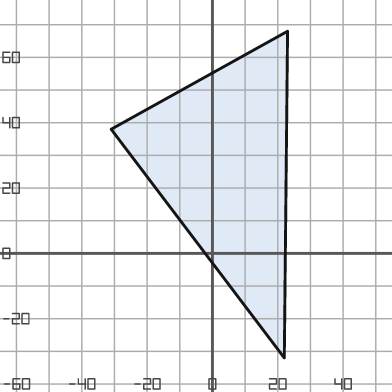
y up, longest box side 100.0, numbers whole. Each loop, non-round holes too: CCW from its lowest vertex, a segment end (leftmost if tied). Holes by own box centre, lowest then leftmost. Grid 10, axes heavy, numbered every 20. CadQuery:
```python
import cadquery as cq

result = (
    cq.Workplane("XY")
    .moveTo(22.0, -32.0)
    .lineTo(23.0, 68.0)
    .lineTo(-31.0, 38.0)
    .close()
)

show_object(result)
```